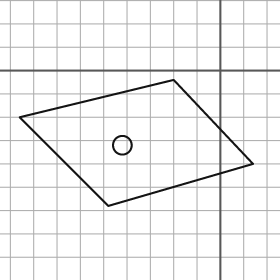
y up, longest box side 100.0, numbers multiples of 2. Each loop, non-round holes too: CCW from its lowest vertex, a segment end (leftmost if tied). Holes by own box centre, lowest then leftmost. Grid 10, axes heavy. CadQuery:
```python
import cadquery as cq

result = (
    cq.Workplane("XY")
    .moveTo(-48.0, -58.0)
    .lineTo(14.0, -40.0)
    .lineTo(-20.0, -4.0)
    .lineTo(-86.0, -20.0)
    .close()
    .moveTo(-42.0, -32.0)
    .circle(4.0)
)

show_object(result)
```